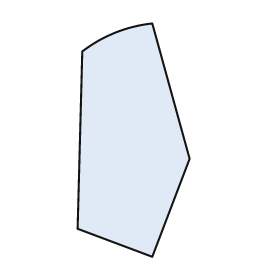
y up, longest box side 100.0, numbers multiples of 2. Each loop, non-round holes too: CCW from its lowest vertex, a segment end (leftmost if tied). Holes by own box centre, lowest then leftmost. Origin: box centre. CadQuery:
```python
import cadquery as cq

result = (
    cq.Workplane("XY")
    .moveTo(8.0, -50.0)
    .lineTo(24.0, -8.0)
    .lineTo(8.0, 50.0)
    .threePointArc((-8.0, 46.0), (-22.0, 38.0))
    .lineTo(-24.0, -38.0)
    .close()
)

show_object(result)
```